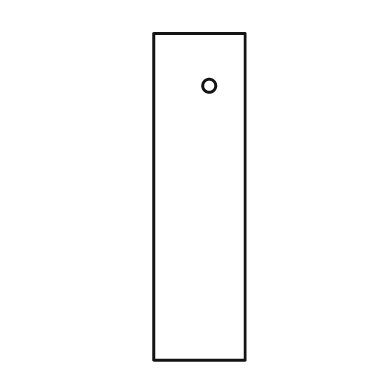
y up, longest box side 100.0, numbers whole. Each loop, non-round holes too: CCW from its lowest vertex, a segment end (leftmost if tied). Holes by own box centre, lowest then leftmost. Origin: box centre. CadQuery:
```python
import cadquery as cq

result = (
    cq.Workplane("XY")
    .moveTo(-14.0, -50.0)
    .lineTo(14.0, -50.0)
    .lineTo(14.0, 50.0)
    .lineTo(-14.0, 50.0)
    .close()
    .moveTo(3.0, 34.0)
    .circle(2.0)
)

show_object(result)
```